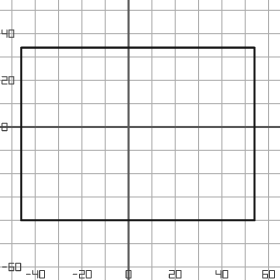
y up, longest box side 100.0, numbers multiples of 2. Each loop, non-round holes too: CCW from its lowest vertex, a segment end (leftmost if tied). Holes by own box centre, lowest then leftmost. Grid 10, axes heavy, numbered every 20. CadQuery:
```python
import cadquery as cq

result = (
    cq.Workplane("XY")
    .moveTo(-46.0, -40.0)
    .lineTo(54.0, -40.0)
    .lineTo(54.0, 34.0)
    .lineTo(-46.0, 34.0)
    .close()
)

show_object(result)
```